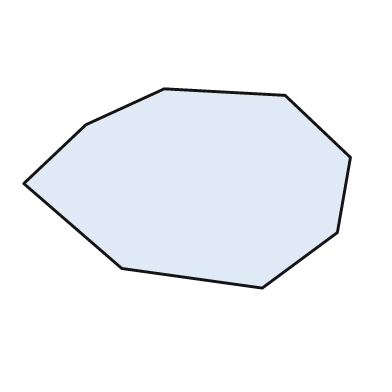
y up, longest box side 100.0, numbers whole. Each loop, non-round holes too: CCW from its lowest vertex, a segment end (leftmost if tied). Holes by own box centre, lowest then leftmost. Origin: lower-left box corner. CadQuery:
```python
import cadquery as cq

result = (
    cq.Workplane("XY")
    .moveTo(73.0, 0.0)
    .lineTo(96.0, 17.0)
    .lineTo(100.0, 40.0)
    .lineTo(80.0, 59.0)
    .lineTo(43.0, 61.0)
    .lineTo(19.0, 50.0)
    .lineTo(0.0, 32.0)
    .lineTo(30.0, 6.0)
    .close()
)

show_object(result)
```